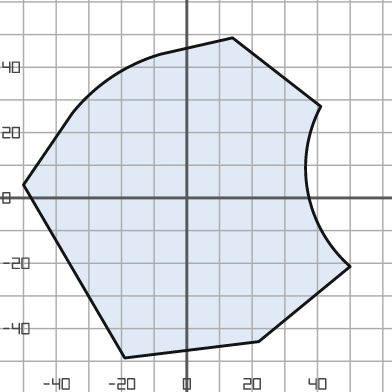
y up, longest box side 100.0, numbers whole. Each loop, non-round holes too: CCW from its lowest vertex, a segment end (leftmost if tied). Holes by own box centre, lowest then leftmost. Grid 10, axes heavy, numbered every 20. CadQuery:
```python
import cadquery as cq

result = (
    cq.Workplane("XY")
    .moveTo(-19.0, -49.0)
    .lineTo(22.0, -44.0)
    .lineTo(50.0, -21.0)
    .threePointArc((37.0, 2.0), (41.0, 28.0))
    .lineTo(14.0, 49.0)
    .lineTo(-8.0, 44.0)
    .threePointArc((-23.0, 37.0), (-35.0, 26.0))
    .lineTo(-50.0, 4.0)
    .close()
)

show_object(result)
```